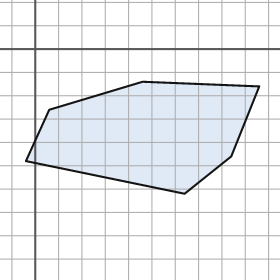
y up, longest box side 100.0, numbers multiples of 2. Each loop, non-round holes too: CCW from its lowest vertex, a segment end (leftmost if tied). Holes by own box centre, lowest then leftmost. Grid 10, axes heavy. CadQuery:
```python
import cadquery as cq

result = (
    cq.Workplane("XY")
    .moveTo(64.0, -62.0)
    .lineTo(84.0, -46.0)
    .lineTo(96.0, -16.0)
    .lineTo(46.0, -14.0)
    .lineTo(6.0, -26.0)
    .lineTo(-4.0, -48.0)
    .close()
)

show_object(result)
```